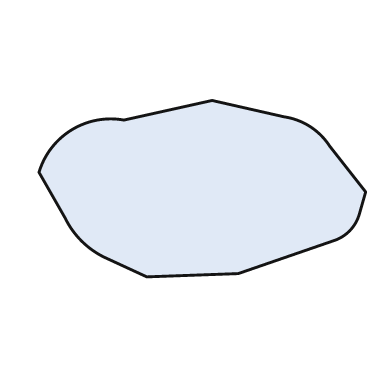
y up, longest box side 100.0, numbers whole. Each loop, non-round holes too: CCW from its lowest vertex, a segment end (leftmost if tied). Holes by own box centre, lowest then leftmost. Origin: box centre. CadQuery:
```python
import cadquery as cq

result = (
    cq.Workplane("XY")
    .moveTo(-17.0, -27.0)
    .lineTo(11.0, -26.0)
    .lineTo(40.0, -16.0)
    .threePointArc((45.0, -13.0), (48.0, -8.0))
    .lineTo(50.0, -1.0)
    .lineTo(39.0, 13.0)
    .threePointArc((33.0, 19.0), (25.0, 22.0))
    .lineTo(3.0, 27.0)
    .lineTo(-24.0, 21.0)
    .threePointArc((-40.0, 18.0), (-50.0, 5.0))
    .lineTo(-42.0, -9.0)
    .threePointArc((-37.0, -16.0), (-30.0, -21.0))
    .close()
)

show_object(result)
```